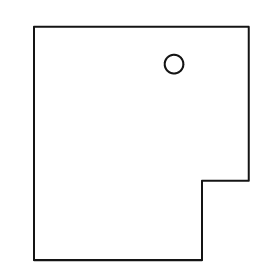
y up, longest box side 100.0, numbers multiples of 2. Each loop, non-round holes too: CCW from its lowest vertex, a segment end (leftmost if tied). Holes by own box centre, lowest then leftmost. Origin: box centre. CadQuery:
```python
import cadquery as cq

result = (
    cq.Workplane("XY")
    .moveTo(-46.0, -50.0)
    .lineTo(26.0, -50.0)
    .lineTo(26.0, -16.0)
    .lineTo(46.0, -16.0)
    .lineTo(46.0, 50.0)
    .lineTo(-46.0, 50.0)
    .close()
    .moveTo(14.0, 34.0)
    .circle(4.0)
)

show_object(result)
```